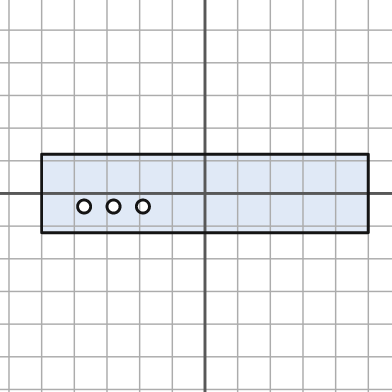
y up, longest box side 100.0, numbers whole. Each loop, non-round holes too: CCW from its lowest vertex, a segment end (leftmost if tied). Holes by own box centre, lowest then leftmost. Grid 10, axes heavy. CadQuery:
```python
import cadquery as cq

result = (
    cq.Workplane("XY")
    .moveTo(-50.0, -12.0)
    .lineTo(50.0, -12.0)
    .lineTo(50.0, 12.0)
    .lineTo(-50.0, 12.0)
    .close()
    .moveTo(-37.0, -4.0)
    .circle(2.0)
    .moveTo(-28.0, -4.0)
    .circle(2.0)
    .moveTo(-19.0, -4.0)
    .circle(2.0)
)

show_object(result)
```